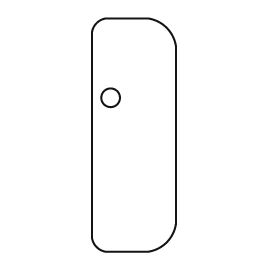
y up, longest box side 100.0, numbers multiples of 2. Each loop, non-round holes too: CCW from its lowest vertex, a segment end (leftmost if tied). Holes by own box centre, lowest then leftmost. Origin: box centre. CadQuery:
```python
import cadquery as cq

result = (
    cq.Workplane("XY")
    .moveTo(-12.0, -50.0)
    .lineTo(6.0, -50.0)
    .threePointArc((14.0, -46.0), (18.0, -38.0))
    .lineTo(18.0, 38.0)
    .threePointArc((14.0, 46.0), (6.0, 50.0))
    .lineTo(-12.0, 50.0)
    .threePointArc((-16.0, 48.0), (-18.0, 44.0))
    .lineTo(-18.0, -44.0)
    .threePointArc((-16.0, -48.0), (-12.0, -50.0))
    .close()
    .moveTo(-10.0, 16.0)
    .circle(4.0)
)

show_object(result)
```